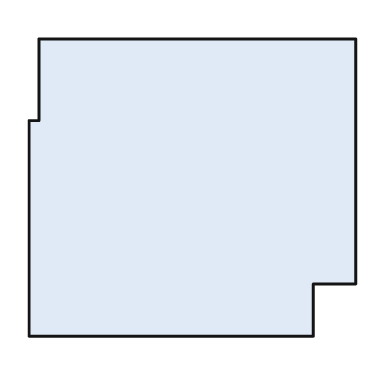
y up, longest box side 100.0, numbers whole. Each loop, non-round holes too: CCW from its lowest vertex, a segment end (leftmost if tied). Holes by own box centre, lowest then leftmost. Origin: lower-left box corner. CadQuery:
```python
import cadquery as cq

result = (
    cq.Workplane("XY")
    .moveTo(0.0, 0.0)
    .lineTo(87.0, 0.0)
    .lineTo(87.0, 16.0)
    .lineTo(100.0, 16.0)
    .lineTo(100.0, 91.0)
    .lineTo(3.0, 91.0)
    .lineTo(3.0, 66.0)
    .lineTo(0.0, 66.0)
    .close()
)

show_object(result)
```